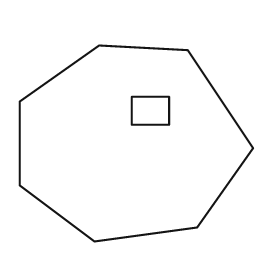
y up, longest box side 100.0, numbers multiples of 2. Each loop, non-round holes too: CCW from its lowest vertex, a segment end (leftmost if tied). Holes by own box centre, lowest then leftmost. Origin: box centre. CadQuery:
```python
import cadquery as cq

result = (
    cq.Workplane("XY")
    .moveTo(-18.0, -42.0)
    .lineTo(26.0, -36.0)
    .lineTo(50.0, -2.0)
    .lineTo(22.0, 40.0)
    .lineTo(-16.0, 42.0)
    .lineTo(-50.0, 18.0)
    .lineTo(-50.0, -18.0)
    .close()
    .moveTo(-2.0, 8.0)
    .lineTo(14.0, 8.0)
    .lineTo(14.0, 20.0)
    .lineTo(-2.0, 20.0)
    .close()
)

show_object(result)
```